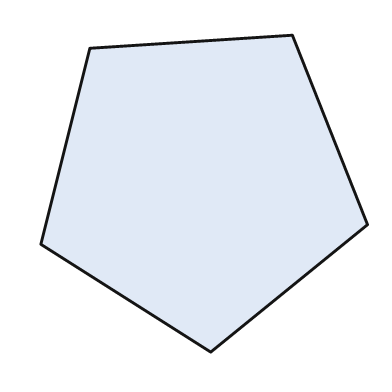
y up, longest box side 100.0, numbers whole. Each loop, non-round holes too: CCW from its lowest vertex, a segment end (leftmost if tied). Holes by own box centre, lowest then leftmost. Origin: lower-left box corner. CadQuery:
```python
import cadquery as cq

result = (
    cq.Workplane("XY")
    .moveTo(52.0, 0.0)
    .lineTo(100.0, 39.0)
    .lineTo(77.0, 97.0)
    .lineTo(15.0, 93.0)
    .lineTo(0.0, 33.0)
    .close()
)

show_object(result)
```